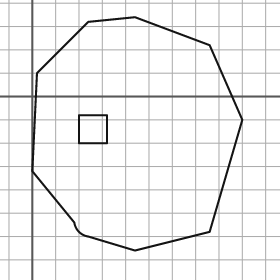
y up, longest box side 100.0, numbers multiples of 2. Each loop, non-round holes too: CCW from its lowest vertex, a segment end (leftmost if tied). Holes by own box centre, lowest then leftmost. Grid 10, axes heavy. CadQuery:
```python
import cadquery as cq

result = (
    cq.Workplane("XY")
    .moveTo(44.0, -66.0)
    .lineTo(76.0, -58.0)
    .lineTo(90.0, -10.0)
    .lineTo(76.0, 22.0)
    .lineTo(44.0, 34.0)
    .lineTo(24.0, 32.0)
    .lineTo(2.0, 10.0)
    .lineTo(0.0, -32.0)
    .lineTo(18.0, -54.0)
    .threePointArc((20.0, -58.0), (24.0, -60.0))
    .close()
    .moveTo(20.0, -20.0)
    .lineTo(32.0, -20.0)
    .lineTo(32.0, -8.0)
    .lineTo(20.0, -8.0)
    .close()
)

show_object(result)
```